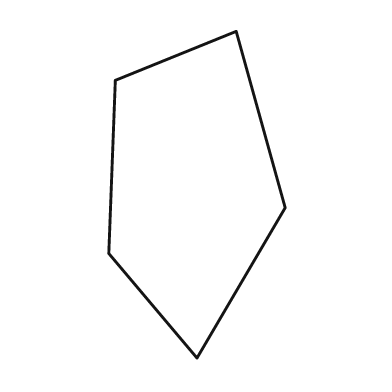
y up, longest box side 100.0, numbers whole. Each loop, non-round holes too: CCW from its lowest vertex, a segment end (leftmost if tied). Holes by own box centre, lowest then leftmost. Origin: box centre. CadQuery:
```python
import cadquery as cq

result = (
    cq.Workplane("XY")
    .moveTo(0.0, -50.0)
    .lineTo(27.0, -4.0)
    .lineTo(12.0, 50.0)
    .lineTo(-25.0, 35.0)
    .lineTo(-27.0, -18.0)
    .close()
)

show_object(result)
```